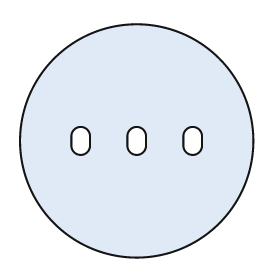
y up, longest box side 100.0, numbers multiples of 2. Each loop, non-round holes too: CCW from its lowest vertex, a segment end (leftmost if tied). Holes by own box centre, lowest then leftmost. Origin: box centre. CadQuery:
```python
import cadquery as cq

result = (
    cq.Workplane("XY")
    .moveTo(0.0, 0.0)
    .circle(50.0)
    .moveTo(-28.0, -2.0)
    .threePointArc((-24.0, -6.0), (-20.0, -2.0))
    .lineTo(-20.0, 2.0)
    .threePointArc((-24.0, 6.0), (-28.0, 2.0))
    .close()
    .moveTo(-4.0, -2.0)
    .threePointArc((0.0, -6.0), (4.0, -2.0))
    .lineTo(4.0, 2.0)
    .threePointArc((0.0, 6.0), (-4.0, 2.0))
    .close()
    .moveTo(20.0, -2.0)
    .threePointArc((24.0, -6.0), (28.0, -2.0))
    .lineTo(28.0, 2.0)
    .threePointArc((24.0, 6.0), (20.0, 2.0))
    .close()
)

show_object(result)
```